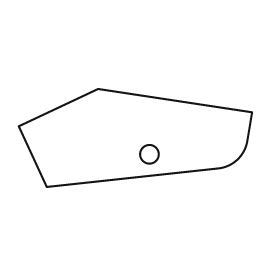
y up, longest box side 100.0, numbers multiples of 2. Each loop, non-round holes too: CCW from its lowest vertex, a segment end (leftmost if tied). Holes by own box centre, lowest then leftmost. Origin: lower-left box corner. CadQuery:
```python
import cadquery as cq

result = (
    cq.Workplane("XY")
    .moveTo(12.0, 0.0)
    .lineTo(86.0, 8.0)
    .threePointArc((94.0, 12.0), (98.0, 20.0))
    .lineTo(100.0, 32.0)
    .lineTo(34.0, 42.0)
    .lineTo(0.0, 26.0)
    .close()
    .moveTo(56.0, 14.0)
    .circle(4.0)
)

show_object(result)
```